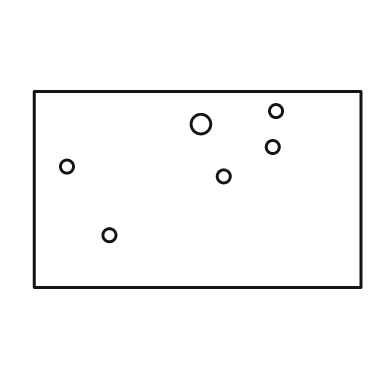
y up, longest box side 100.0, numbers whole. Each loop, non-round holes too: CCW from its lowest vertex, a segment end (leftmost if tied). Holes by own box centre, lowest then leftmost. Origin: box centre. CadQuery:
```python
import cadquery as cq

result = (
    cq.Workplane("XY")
    .moveTo(-50.0, -30.0)
    .lineTo(50.0, -30.0)
    .lineTo(50.0, 30.0)
    .lineTo(-50.0, 30.0)
    .close()
    .moveTo(-27.0, -14.0)
    .circle(2.0)
    .moveTo(8.0, 4.0)
    .circle(2.0)
    .moveTo(-40.0, 7.0)
    .circle(2.0)
    .moveTo(23.0, 13.0)
    .circle(2.0)
    .moveTo(1.0, 20.0)
    .circle(3.0)
    .moveTo(24.0, 24.0)
    .circle(2.0)
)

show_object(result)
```